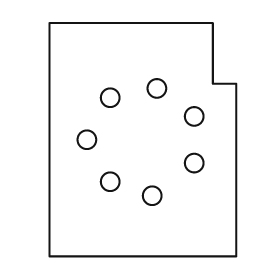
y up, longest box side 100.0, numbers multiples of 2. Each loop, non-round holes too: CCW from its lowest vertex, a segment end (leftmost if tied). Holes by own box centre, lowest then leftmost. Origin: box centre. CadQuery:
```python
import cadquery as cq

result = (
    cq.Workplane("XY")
    .moveTo(-40.0, -50.0)
    .lineTo(40.0, -50.0)
    .lineTo(40.0, 24.0)
    .lineTo(30.0, 24.0)
    .lineTo(30.0, 50.0)
    .lineTo(-40.0, 50.0)
    .close()
    .moveTo(4.0, -24.0)
    .circle(4.0)
    .moveTo(-14.0, -18.0)
    .circle(4.0)
    .moveTo(22.0, -10.0)
    .circle(4.0)
    .moveTo(-24.0, 0.0)
    .circle(4.0)
    .moveTo(22.0, 10.0)
    .circle(4.0)
    .moveTo(-14.0, 18.0)
    .circle(4.0)
    .moveTo(6.0, 22.0)
    .circle(4.0)
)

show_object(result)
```